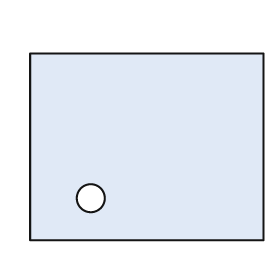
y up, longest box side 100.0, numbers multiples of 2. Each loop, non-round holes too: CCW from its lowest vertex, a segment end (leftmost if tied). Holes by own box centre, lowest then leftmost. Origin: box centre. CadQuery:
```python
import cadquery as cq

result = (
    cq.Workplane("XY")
    .moveTo(-50.0, -40.0)
    .lineTo(50.0, -40.0)
    .lineTo(50.0, 40.0)
    .lineTo(-50.0, 40.0)
    .close()
    .moveTo(-24.0, -22.0)
    .circle(6.0)
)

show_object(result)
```